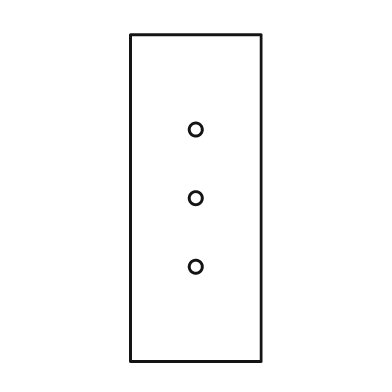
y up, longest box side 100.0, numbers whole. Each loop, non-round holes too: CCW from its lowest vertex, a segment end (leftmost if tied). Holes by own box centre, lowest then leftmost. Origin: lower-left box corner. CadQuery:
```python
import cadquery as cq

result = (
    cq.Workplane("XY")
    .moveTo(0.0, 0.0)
    .lineTo(40.0, 0.0)
    .lineTo(40.0, 100.0)
    .lineTo(0.0, 100.0)
    .close()
    .moveTo(20.0, 29.0)
    .circle(2.0)
    .moveTo(20.0, 50.0)
    .circle(2.0)
    .moveTo(20.0, 71.0)
    .circle(2.0)
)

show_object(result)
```